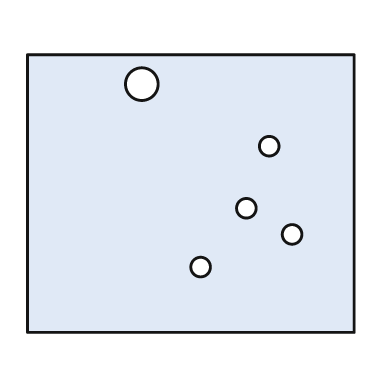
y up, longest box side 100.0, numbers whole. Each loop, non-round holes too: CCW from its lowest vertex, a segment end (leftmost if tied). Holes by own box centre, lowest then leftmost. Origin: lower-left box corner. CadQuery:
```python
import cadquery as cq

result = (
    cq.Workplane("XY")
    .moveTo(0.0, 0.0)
    .lineTo(100.0, 0.0)
    .lineTo(100.0, 85.0)
    .lineTo(0.0, 85.0)
    .close()
    .moveTo(53.0, 20.0)
    .circle(3.0)
    .moveTo(81.0, 30.0)
    .circle(3.0)
    .moveTo(67.0, 38.0)
    .circle(3.0)
    .moveTo(74.0, 57.0)
    .circle(3.0)
    .moveTo(35.0, 76.0)
    .circle(5.0)
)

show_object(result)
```